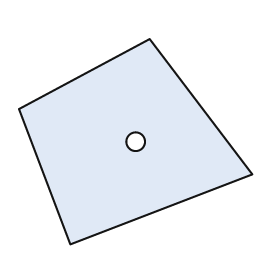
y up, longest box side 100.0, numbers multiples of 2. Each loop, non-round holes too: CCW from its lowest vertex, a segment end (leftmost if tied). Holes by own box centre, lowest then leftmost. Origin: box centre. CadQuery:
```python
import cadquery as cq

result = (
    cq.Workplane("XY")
    .moveTo(-28.0, -44.0)
    .lineTo(50.0, -14.0)
    .lineTo(6.0, 44.0)
    .lineTo(-50.0, 14.0)
    .close()
    .moveTo(0.0, 0.0)
    .circle(4.0)
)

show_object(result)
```